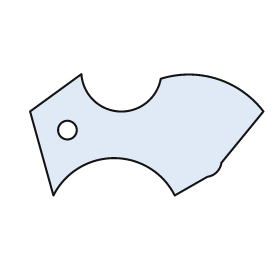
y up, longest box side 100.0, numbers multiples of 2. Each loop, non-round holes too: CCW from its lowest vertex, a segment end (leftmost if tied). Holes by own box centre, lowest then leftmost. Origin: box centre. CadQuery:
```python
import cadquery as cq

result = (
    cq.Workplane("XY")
    .moveTo(-40.0, -26.0)
    .threePointArc((-14.0, -10.0), (12.0, -26.0))
    .lineTo(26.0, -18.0)
    .threePointArc((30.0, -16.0), (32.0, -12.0))
    .lineTo(50.0, 10.0)
    .threePointArc((30.0, 24.0), (6.0, 24.0))
    .threePointArc((-12.0, 10.0), (-28.0, 26.0))
    .lineTo(-50.0, 10.0)
    .close()
    .moveTo(-34.0, 2.0)
    .circle(4.0)
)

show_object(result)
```